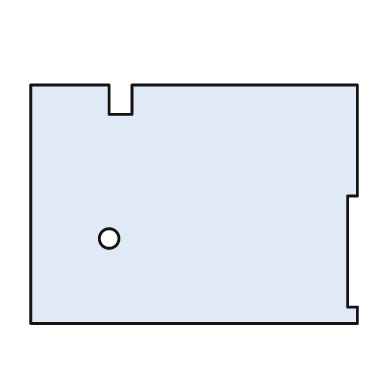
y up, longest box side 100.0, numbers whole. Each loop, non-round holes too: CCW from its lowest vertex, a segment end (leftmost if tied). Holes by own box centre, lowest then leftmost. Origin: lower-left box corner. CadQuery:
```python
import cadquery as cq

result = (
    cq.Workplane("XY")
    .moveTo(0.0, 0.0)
    .lineTo(100.0, 0.0)
    .lineTo(100.0, 5.0)
    .lineTo(97.0, 5.0)
    .lineTo(97.0, 39.0)
    .lineTo(100.0, 39.0)
    .lineTo(100.0, 73.0)
    .lineTo(31.0, 73.0)
    .lineTo(31.0, 64.0)
    .lineTo(24.0, 64.0)
    .lineTo(24.0, 73.0)
    .lineTo(0.0, 73.0)
    .close()
    .moveTo(24.0, 26.0)
    .circle(3.0)
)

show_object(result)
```